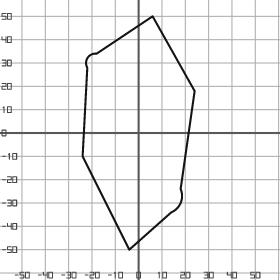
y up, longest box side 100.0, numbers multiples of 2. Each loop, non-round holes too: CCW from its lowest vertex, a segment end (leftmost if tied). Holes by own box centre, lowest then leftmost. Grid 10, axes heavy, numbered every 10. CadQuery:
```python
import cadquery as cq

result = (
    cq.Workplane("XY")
    .moveTo(-4.0, -50.0)
    .lineTo(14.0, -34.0)
    .threePointArc((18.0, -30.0), (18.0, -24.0))
    .lineTo(24.0, 18.0)
    .lineTo(6.0, 50.0)
    .lineTo(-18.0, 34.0)
    .threePointArc((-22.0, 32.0), (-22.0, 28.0))
    .lineTo(-24.0, -10.0)
    .close()
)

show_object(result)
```